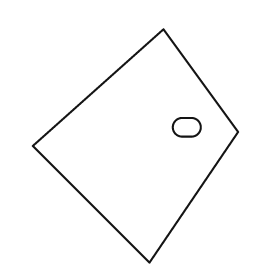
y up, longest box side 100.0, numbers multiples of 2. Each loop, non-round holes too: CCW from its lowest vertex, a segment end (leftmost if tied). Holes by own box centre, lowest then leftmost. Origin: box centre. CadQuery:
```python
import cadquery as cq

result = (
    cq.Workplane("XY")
    .moveTo(6.0, -50.0)
    .lineTo(44.0, 6.0)
    .lineTo(12.0, 50.0)
    .lineTo(-44.0, 0.0)
    .close()
    .moveTo(20.0, 4.0)
    .lineTo(24.0, 4.0)
    .threePointArc((28.0, 8.0), (24.0, 12.0))
    .lineTo(20.0, 12.0)
    .threePointArc((16.0, 8.0), (20.0, 4.0))
    .close()
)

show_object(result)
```